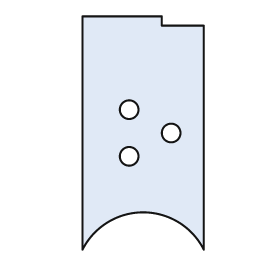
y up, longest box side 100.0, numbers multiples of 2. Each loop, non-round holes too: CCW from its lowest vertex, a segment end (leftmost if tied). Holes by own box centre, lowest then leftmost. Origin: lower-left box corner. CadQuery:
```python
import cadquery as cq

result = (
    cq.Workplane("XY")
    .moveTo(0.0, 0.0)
    .threePointArc((26.0, 16.0), (52.0, 0.0))
    .lineTo(52.0, 96.0)
    .lineTo(34.0, 96.0)
    .lineTo(34.0, 100.0)
    .lineTo(0.0, 100.0)
    .close()
    .moveTo(20.0, 40.0)
    .circle(4.0)
    .moveTo(38.0, 50.0)
    .circle(4.0)
    .moveTo(20.0, 60.0)
    .circle(4.0)
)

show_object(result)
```